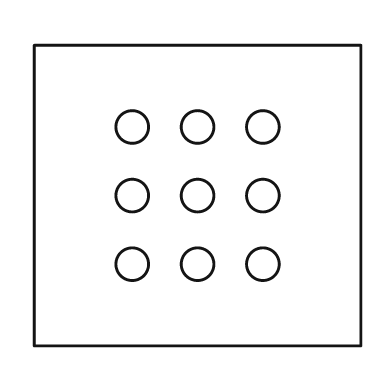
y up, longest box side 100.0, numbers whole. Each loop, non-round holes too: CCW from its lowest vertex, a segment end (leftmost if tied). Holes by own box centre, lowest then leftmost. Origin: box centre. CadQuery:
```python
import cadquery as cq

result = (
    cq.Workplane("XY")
    .moveTo(-50.0, -46.0)
    .lineTo(50.0, -46.0)
    .lineTo(50.0, 46.0)
    .lineTo(-50.0, 46.0)
    .close()
    .moveTo(-20.0, -21.0)
    .circle(5.0)
    .moveTo(0.0, -21.0)
    .circle(5.0)
    .moveTo(20.0, -21.0)
    .circle(5.0)
    .moveTo(-20.0, 0.0)
    .circle(5.0)
    .moveTo(0.0, 0.0)
    .circle(5.0)
    .moveTo(20.0, 0.0)
    .circle(5.0)
    .moveTo(-20.0, 21.0)
    .circle(5.0)
    .moveTo(0.0, 21.0)
    .circle(5.0)
    .moveTo(20.0, 21.0)
    .circle(5.0)
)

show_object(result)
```